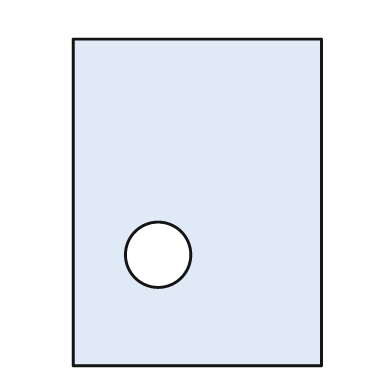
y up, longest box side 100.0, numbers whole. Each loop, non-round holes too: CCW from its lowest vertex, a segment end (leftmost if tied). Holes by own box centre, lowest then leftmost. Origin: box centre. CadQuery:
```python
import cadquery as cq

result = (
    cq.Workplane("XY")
    .moveTo(-38.0, -50.0)
    .lineTo(38.0, -50.0)
    .lineTo(38.0, 50.0)
    .lineTo(-38.0, 50.0)
    .close()
    .moveTo(-12.0, -16.0)
    .circle(10.0)
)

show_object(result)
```